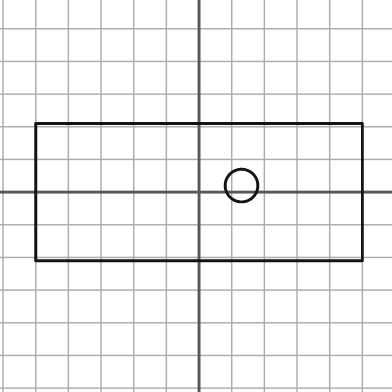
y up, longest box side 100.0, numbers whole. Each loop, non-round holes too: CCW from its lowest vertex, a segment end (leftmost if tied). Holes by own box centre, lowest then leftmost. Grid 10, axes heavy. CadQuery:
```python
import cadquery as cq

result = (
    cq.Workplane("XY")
    .moveTo(-50.0, -21.0)
    .lineTo(50.0, -21.0)
    .lineTo(50.0, 21.0)
    .lineTo(-50.0, 21.0)
    .close()
    .moveTo(13.0, 2.0)
    .circle(5.0)
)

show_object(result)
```